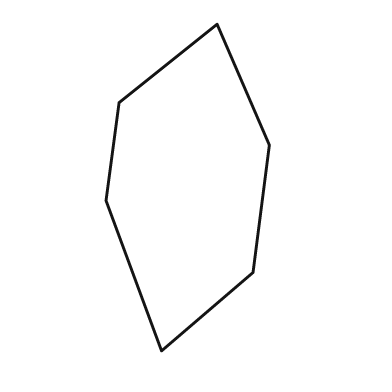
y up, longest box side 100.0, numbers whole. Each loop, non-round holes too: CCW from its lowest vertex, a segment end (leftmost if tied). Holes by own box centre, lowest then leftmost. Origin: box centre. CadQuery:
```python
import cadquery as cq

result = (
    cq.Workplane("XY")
    .moveTo(-8.0, -50.0)
    .lineTo(20.0, -26.0)
    .lineTo(25.0, 13.0)
    .lineTo(9.0, 50.0)
    .lineTo(-21.0, 26.0)
    .lineTo(-25.0, -4.0)
    .close()
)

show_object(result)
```